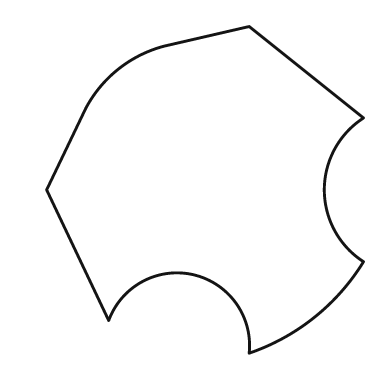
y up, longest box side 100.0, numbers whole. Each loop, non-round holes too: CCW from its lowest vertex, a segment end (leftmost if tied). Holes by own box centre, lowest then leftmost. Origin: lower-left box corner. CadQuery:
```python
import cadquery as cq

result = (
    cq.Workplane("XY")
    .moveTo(62.0, 0.0)
    .threePointArc((82.0, 11.0), (97.0, 28.0))
    .threePointArc((85.0, 50.0), (97.0, 72.0))
    .lineTo(62.0, 100.0)
    .lineTo(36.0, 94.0)
    .threePointArc((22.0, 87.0), (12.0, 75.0))
    .lineTo(0.0, 50.0)
    .lineTo(19.0, 10.0)
    .threePointArc((45.0, 24.0), (62.0, 0.0))
    .close()
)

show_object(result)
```